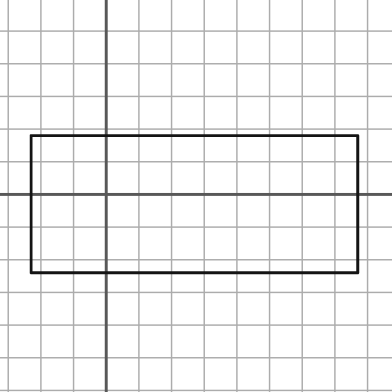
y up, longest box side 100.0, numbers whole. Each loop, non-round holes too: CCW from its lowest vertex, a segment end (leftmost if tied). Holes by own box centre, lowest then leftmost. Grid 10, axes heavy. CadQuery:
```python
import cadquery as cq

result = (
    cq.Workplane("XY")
    .moveTo(-23.0, -24.0)
    .lineTo(77.0, -24.0)
    .lineTo(77.0, 18.0)
    .lineTo(-23.0, 18.0)
    .close()
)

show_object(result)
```